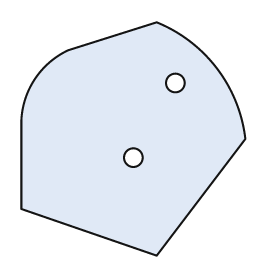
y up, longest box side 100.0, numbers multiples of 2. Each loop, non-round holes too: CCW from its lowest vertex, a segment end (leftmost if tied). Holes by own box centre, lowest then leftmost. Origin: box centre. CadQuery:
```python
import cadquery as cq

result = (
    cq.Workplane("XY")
    .moveTo(10.0, -50.0)
    .lineTo(48.0, 0.0)
    .threePointArc((36.0, 30.0), (10.0, 50.0))
    .lineTo(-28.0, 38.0)
    .threePointArc((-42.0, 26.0), (-48.0, 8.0))
    .lineTo(-48.0, -30.0)
    .close()
    .moveTo(0.0, -8.0)
    .circle(4.0)
    .moveTo(18.0, 24.0)
    .circle(4.0)
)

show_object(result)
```